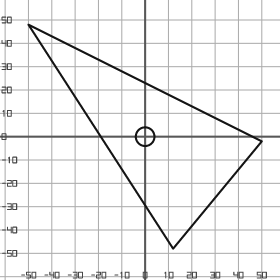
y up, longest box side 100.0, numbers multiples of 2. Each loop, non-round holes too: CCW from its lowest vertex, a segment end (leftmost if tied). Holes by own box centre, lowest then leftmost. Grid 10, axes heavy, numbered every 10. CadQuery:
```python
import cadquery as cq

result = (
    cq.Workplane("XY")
    .moveTo(12.0, -48.0)
    .lineTo(50.0, -2.0)
    .lineTo(-50.0, 48.0)
    .close()
    .moveTo(0.0, 0.0)
    .circle(4.0)
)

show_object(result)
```